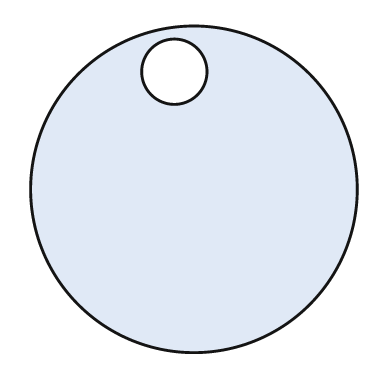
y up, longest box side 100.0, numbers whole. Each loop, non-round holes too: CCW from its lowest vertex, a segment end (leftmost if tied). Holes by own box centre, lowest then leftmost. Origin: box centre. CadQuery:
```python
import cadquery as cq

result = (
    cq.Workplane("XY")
    .moveTo(0.0, 0.0)
    .circle(50.0)
    .moveTo(-6.0, 36.0)
    .circle(10.0)
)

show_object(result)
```